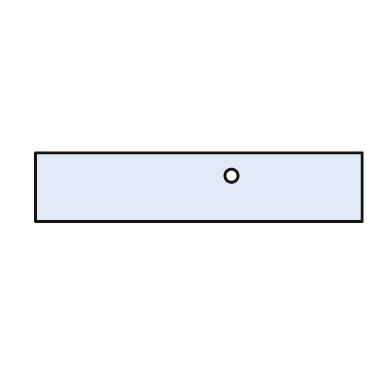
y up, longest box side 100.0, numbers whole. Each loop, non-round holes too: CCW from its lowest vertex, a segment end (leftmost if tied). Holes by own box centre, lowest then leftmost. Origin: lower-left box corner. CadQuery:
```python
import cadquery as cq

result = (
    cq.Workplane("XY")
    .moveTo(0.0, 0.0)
    .lineTo(100.0, 0.0)
    .lineTo(100.0, 21.0)
    .lineTo(0.0, 21.0)
    .close()
    .moveTo(60.0, 14.0)
    .circle(2.0)
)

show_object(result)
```